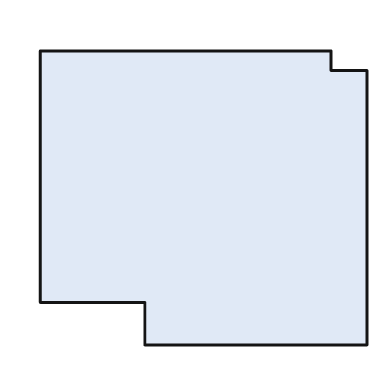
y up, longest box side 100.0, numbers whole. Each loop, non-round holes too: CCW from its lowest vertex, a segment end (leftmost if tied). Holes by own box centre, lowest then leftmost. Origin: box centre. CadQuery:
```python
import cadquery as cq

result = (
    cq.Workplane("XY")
    .moveTo(-18.0, -45.0)
    .lineTo(50.0, -45.0)
    .lineTo(50.0, 39.0)
    .lineTo(39.0, 39.0)
    .lineTo(39.0, 45.0)
    .lineTo(-50.0, 45.0)
    .lineTo(-50.0, -32.0)
    .lineTo(-18.0, -32.0)
    .close()
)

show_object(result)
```